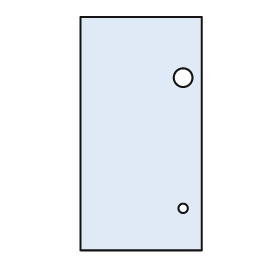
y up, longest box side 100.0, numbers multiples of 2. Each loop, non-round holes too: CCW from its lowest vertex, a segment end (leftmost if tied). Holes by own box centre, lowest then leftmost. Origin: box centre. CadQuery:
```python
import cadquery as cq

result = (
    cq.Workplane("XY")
    .moveTo(-26.0, -50.0)
    .lineTo(26.0, -50.0)
    .lineTo(26.0, 50.0)
    .lineTo(-26.0, 50.0)
    .close()
    .moveTo(18.0, -32.0)
    .circle(2.0)
    .moveTo(18.0, 24.0)
    .circle(4.0)
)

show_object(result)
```